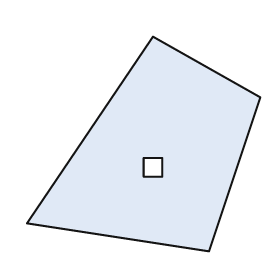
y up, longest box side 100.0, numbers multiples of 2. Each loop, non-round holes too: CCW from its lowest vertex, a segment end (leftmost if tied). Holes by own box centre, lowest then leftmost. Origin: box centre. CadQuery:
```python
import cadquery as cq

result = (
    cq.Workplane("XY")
    .moveTo(28.0, -46.0)
    .lineTo(50.0, 20.0)
    .lineTo(4.0, 46.0)
    .lineTo(-50.0, -34.0)
    .close()
    .moveTo(0.0, -14.0)
    .lineTo(8.0, -14.0)
    .lineTo(8.0, -6.0)
    .lineTo(0.0, -6.0)
    .close()
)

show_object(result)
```